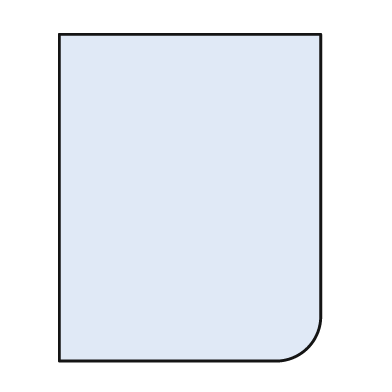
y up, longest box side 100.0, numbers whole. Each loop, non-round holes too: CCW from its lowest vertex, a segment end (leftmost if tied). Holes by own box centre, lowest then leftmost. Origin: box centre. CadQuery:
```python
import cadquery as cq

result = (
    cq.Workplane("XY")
    .moveTo(-40.0, -50.0)
    .lineTo(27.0, -50.0)
    .threePointArc((36.0, -46.0), (40.0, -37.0))
    .lineTo(40.0, 50.0)
    .lineTo(-40.0, 50.0)
    .close()
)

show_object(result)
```